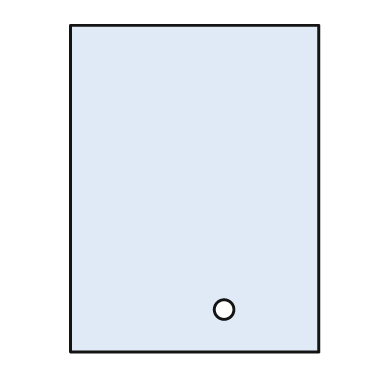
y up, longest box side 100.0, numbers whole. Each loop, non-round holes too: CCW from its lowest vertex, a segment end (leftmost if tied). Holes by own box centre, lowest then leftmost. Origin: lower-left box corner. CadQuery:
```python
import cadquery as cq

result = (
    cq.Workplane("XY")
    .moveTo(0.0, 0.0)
    .lineTo(76.0, 0.0)
    .lineTo(76.0, 100.0)
    .lineTo(0.0, 100.0)
    .close()
    .moveTo(47.0, 13.0)
    .circle(3.0)
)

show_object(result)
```